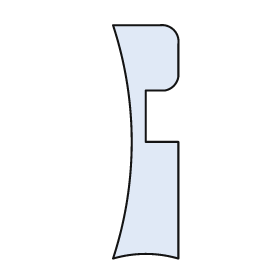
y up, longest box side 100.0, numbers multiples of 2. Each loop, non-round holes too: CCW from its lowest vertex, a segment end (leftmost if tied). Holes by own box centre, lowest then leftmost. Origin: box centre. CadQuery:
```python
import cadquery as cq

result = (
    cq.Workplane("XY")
    .moveTo(-14.0, -50.0)
    .threePointArc((0.0, -48.0), (14.0, -50.0))
    .lineTo(14.0, 0.0)
    .lineTo(0.0, 0.0)
    .lineTo(0.0, 22.0)
    .lineTo(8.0, 22.0)
    .threePointArc((12.0, 24.0), (14.0, 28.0))
    .lineTo(14.0, 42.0)
    .threePointArc((12.0, 48.0), (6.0, 50.0))
    .lineTo(-14.0, 50.0)
    .threePointArc((-6.0, 0.0), (-14.0, -50.0))
    .close()
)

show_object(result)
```